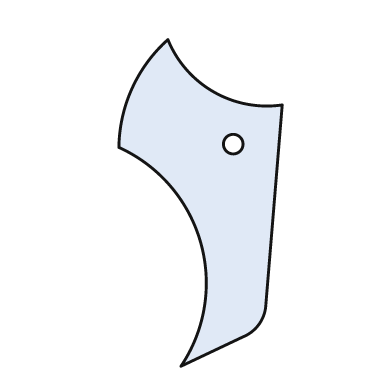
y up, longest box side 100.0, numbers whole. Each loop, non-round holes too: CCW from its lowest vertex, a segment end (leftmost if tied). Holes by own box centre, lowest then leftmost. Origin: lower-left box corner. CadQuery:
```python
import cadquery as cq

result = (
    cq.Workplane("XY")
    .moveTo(19.0, 0.0)
    .lineTo(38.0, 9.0)
    .threePointArc((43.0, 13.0), (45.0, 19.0))
    .lineTo(50.0, 80.0)
    .threePointArc((29.0, 84.0), (15.0, 100.0))
    .threePointArc((4.0, 85.0), (0.0, 67.0))
    .threePointArc((25.0, 38.0), (19.0, 0.0))
    .close()
    .moveTo(35.0, 68.0)
    .circle(3.0)
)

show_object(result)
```